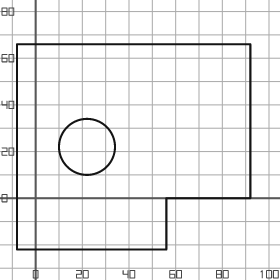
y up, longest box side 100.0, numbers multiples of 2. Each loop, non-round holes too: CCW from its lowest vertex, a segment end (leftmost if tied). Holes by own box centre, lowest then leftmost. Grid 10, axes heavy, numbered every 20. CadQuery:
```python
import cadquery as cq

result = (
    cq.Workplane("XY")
    .moveTo(-8.0, -22.0)
    .lineTo(56.0, -22.0)
    .lineTo(56.0, 0.0)
    .lineTo(92.0, 0.0)
    .lineTo(92.0, 66.0)
    .lineTo(-8.0, 66.0)
    .close()
    .moveTo(22.0, 22.0)
    .circle(12.0)
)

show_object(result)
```